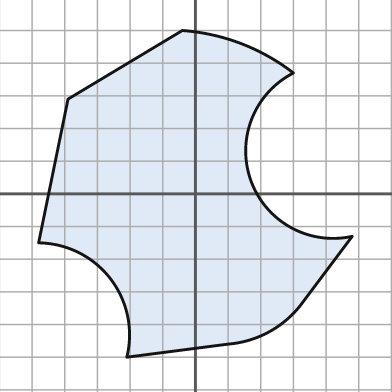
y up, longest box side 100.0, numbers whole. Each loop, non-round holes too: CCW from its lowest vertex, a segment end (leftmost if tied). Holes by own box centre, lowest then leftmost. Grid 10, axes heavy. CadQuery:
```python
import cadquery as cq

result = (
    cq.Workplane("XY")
    .moveTo(-21.0, -50.0)
    .lineTo(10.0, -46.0)
    .threePointArc((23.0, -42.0), (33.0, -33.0))
    .lineTo(48.0, -13.0)
    .threePointArc((17.0, 4.0), (30.0, 37.0))
    .threePointArc((14.0, 46.0), (-4.0, 50.0))
    .lineTo(-39.0, 29.0)
    .lineTo(-48.0, -15.0)
    .threePointArc((-26.0, -26.0), (-21.0, -50.0))
    .close()
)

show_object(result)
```